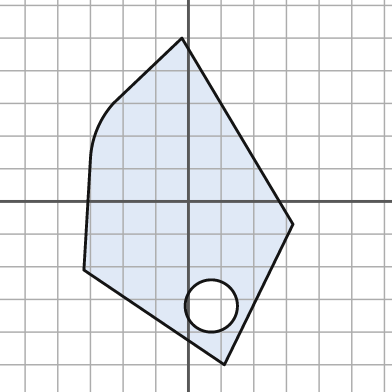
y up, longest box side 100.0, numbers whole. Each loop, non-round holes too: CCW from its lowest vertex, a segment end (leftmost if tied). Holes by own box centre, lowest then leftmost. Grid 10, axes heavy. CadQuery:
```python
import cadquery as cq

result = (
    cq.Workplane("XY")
    .moveTo(11.0, -50.0)
    .lineTo(32.0, -7.0)
    .lineTo(-2.0, 50.0)
    .lineTo(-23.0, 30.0)
    .threePointArc((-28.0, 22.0), (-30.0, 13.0))
    .lineTo(-32.0, -21.0)
    .close()
    .moveTo(7.0, -32.0)
    .circle(8.0)
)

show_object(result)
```